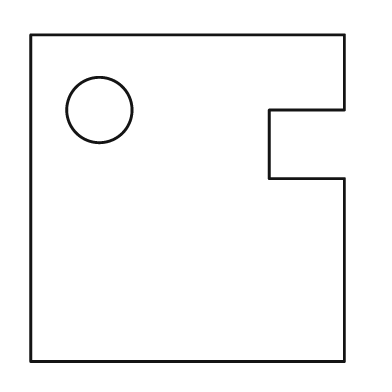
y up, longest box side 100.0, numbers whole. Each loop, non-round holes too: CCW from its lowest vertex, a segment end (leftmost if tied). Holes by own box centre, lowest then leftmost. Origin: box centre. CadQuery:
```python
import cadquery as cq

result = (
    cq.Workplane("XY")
    .moveTo(-48.0, -50.0)
    .lineTo(48.0, -50.0)
    .lineTo(48.0, 6.0)
    .lineTo(25.0, 6.0)
    .lineTo(25.0, 27.0)
    .lineTo(48.0, 27.0)
    .lineTo(48.0, 50.0)
    .lineTo(-48.0, 50.0)
    .close()
    .moveTo(-27.0, 27.0)
    .circle(10.0)
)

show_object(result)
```